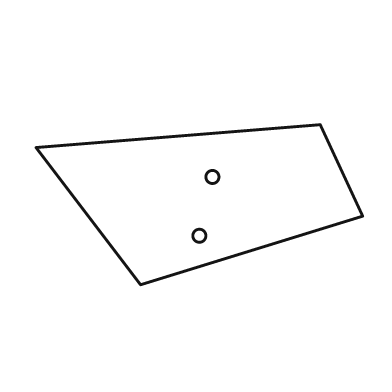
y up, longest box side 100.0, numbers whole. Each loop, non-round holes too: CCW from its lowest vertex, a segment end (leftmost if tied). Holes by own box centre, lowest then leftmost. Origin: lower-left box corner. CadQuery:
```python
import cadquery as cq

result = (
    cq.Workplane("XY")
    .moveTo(32.0, 0.0)
    .lineTo(100.0, 21.0)
    .lineTo(87.0, 49.0)
    .lineTo(0.0, 42.0)
    .close()
    .moveTo(50.0, 15.0)
    .circle(2.0)
    .moveTo(54.0, 33.0)
    .circle(2.0)
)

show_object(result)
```